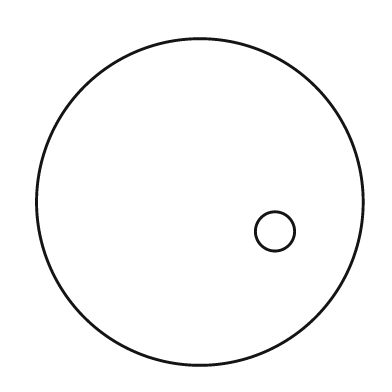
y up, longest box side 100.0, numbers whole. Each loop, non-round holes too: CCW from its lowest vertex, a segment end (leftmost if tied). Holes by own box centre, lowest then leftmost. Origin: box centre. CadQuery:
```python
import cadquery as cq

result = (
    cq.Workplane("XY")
    .moveTo(0.0, 0.0)
    .circle(50.0)
    .moveTo(23.0, -9.0)
    .circle(6.0)
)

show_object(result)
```